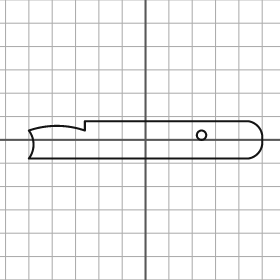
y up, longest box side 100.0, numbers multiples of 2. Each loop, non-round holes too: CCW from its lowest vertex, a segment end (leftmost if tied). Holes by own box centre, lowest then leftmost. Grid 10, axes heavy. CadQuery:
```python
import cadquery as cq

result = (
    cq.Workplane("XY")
    .moveTo(-50.0, -8.0)
    .lineTo(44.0, -8.0)
    .threePointArc((48.0, -6.0), (50.0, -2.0))
    .lineTo(50.0, 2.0)
    .threePointArc((48.0, 6.0), (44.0, 8.0))
    .lineTo(-26.0, 8.0)
    .lineTo(-26.0, 4.0)
    .threePointArc((-38.0, 6.0), (-50.0, 4.0))
    .threePointArc((-48.0, -2.0), (-50.0, -8.0))
    .close()
    .moveTo(24.0, 2.0)
    .circle(2.0)
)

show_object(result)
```